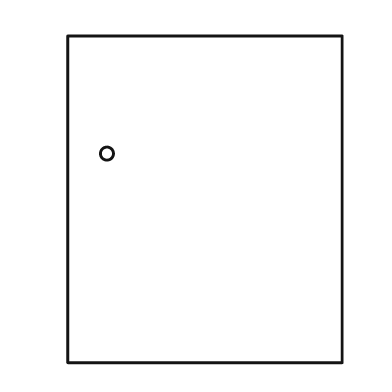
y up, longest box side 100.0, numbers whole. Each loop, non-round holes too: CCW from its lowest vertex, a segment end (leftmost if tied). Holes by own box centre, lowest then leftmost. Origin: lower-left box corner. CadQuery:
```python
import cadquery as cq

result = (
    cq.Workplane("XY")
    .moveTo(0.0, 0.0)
    .lineTo(84.0, 0.0)
    .lineTo(84.0, 100.0)
    .lineTo(0.0, 100.0)
    .close()
    .moveTo(12.0, 64.0)
    .circle(2.0)
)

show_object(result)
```